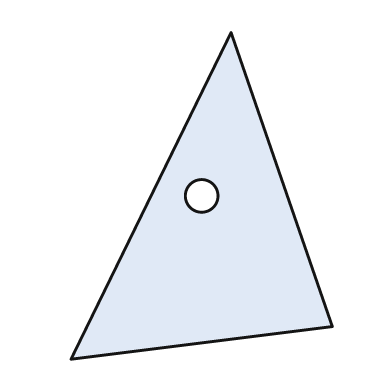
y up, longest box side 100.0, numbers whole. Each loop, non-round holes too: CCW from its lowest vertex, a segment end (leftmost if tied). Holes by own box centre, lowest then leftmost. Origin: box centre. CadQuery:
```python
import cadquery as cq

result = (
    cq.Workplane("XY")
    .moveTo(-40.0, -50.0)
    .lineTo(40.0, -40.0)
    .lineTo(9.0, 50.0)
    .close()
    .moveTo(0.0, 0.0)
    .circle(5.0)
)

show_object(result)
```